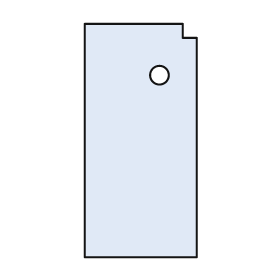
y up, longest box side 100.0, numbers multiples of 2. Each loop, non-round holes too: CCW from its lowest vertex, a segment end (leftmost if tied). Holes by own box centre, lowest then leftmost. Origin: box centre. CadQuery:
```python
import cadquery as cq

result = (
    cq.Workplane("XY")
    .moveTo(-24.0, -50.0)
    .lineTo(24.0, -50.0)
    .lineTo(24.0, 44.0)
    .lineTo(18.0, 44.0)
    .lineTo(18.0, 50.0)
    .lineTo(-24.0, 50.0)
    .close()
    .moveTo(8.0, 28.0)
    .circle(4.0)
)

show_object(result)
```